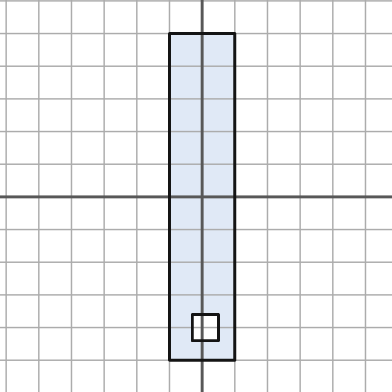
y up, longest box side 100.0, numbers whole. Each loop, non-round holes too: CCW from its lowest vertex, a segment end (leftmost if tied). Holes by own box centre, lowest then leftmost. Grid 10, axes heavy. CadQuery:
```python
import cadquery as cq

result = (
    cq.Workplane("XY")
    .moveTo(-10.0, -50.0)
    .lineTo(10.0, -50.0)
    .lineTo(10.0, 50.0)
    .lineTo(-10.0, 50.0)
    .close()
    .moveTo(-3.0, -44.0)
    .lineTo(5.0, -44.0)
    .lineTo(5.0, -36.0)
    .lineTo(-3.0, -36.0)
    .close()
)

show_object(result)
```